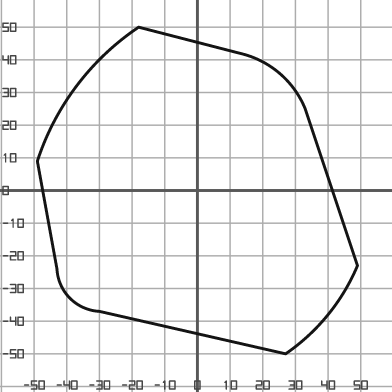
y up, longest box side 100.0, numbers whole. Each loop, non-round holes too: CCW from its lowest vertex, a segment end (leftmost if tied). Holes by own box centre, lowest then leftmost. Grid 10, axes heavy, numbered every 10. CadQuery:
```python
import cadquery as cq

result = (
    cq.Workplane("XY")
    .moveTo(27.0, -50.0)
    .threePointArc((40.0, -38.0), (49.0, -23.0))
    .lineTo(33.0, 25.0)
    .threePointArc((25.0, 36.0), (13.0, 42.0))
    .lineTo(-18.0, 50.0)
    .threePointArc((-37.0, 32.0), (-49.0, 9.0))
    .lineTo(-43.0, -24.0)
    .threePointArc((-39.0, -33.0), (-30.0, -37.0))
    .close()
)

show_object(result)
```